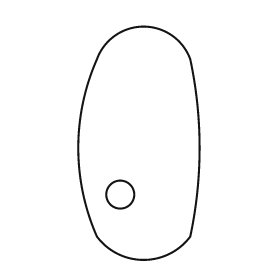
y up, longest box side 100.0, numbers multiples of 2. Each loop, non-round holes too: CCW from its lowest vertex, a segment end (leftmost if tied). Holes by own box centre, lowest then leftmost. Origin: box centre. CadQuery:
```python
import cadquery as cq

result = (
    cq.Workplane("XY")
    .moveTo(-18.0, -40.0)
    .threePointArc((2.0, -50.0), (22.0, -40.0))
    .threePointArc((26.0, -2.0), (22.0, 36.0))
    .threePointArc((2.0, 50.0), (-18.0, 36.0))
    .threePointArc((-26.0, -2.0), (-18.0, -40.0))
    .close()
    .moveTo(-8.0, -22.0)
    .circle(6.0)
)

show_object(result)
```